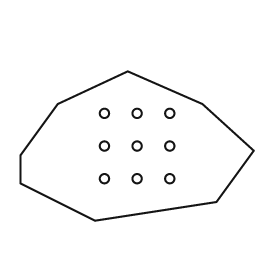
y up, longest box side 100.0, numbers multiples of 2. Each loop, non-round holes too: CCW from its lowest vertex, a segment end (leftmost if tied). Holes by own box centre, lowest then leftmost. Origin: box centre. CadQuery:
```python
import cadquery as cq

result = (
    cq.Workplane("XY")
    .moveTo(-18.0, -32.0)
    .lineTo(34.0, -24.0)
    .lineTo(50.0, -2.0)
    .lineTo(28.0, 18.0)
    .lineTo(-4.0, 32.0)
    .lineTo(-34.0, 18.0)
    .lineTo(-50.0, -4.0)
    .lineTo(-50.0, -16.0)
    .close()
    .moveTo(-14.0, -14.0)
    .circle(2.0)
    .moveTo(0.0, -14.0)
    .circle(2.0)
    .moveTo(14.0, -14.0)
    .circle(2.0)
    .moveTo(-14.0, 0.0)
    .circle(2.0)
    .moveTo(0.0, 0.0)
    .circle(2.0)
    .moveTo(14.0, 0.0)
    .circle(2.0)
    .moveTo(-14.0, 14.0)
    .circle(2.0)
    .moveTo(0.0, 14.0)
    .circle(2.0)
    .moveTo(14.0, 14.0)
    .circle(2.0)
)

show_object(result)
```